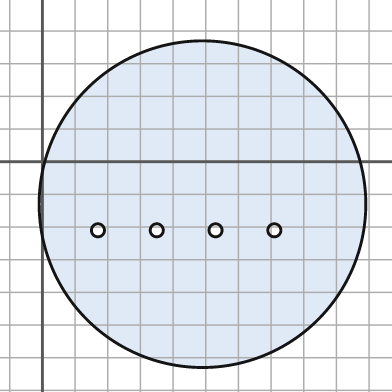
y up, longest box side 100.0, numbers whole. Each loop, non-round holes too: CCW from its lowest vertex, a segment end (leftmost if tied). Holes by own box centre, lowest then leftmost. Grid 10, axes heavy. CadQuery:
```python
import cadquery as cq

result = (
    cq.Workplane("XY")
    .moveTo(49.0, -13.0)
    .circle(50.0)
    .moveTo(17.0, -21.0)
    .circle(2.0)
    .moveTo(35.0, -21.0)
    .circle(2.0)
    .moveTo(53.0, -21.0)
    .circle(2.0)
    .moveTo(71.0, -21.0)
    .circle(2.0)
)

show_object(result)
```